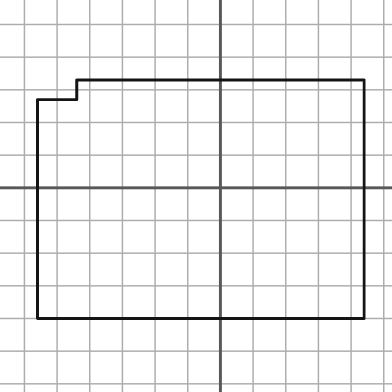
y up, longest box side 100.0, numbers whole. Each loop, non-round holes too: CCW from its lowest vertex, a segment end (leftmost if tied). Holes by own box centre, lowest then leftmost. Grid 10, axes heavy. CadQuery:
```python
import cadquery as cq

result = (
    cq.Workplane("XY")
    .moveTo(-56.0, -40.0)
    .lineTo(44.0, -40.0)
    .lineTo(44.0, 33.0)
    .lineTo(-44.0, 33.0)
    .lineTo(-44.0, 27.0)
    .lineTo(-56.0, 27.0)
    .close()
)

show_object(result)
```